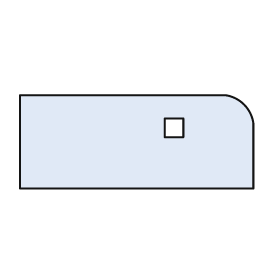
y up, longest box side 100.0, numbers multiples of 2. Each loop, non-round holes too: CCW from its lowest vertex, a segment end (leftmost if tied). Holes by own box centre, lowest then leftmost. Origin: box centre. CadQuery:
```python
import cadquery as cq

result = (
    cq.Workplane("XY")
    .moveTo(-50.0, -20.0)
    .lineTo(50.0, -20.0)
    .lineTo(50.0, 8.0)
    .threePointArc((46.0, 16.0), (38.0, 20.0))
    .lineTo(-50.0, 20.0)
    .close()
    .moveTo(12.0, 2.0)
    .lineTo(20.0, 2.0)
    .lineTo(20.0, 10.0)
    .lineTo(12.0, 10.0)
    .close()
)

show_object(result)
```